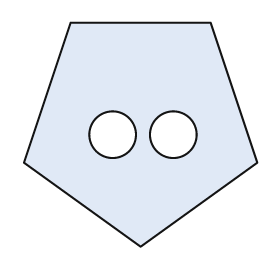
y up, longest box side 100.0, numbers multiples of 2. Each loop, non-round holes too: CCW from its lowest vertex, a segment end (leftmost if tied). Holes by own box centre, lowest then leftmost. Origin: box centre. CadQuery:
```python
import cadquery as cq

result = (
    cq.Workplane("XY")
    .moveTo(0.0, -48.0)
    .lineTo(50.0, -12.0)
    .lineTo(30.0, 48.0)
    .lineTo(-30.0, 48.0)
    .lineTo(-50.0, -12.0)
    .close()
    .moveTo(-12.0, 0.0)
    .circle(10.0)
    .moveTo(14.0, 0.0)
    .circle(10.0)
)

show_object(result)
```